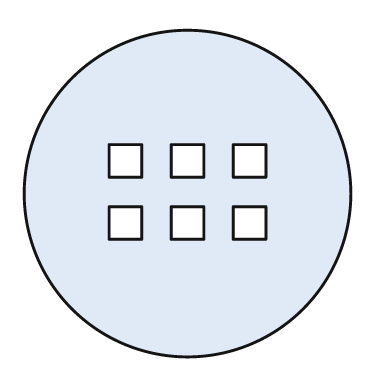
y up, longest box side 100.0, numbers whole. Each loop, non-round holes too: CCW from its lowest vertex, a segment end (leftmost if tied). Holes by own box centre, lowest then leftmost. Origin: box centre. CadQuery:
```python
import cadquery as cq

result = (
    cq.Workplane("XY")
    .moveTo(0.0, 0.0)
    .circle(50.0)
    .moveTo(-24.0, -14.0)
    .lineTo(-14.0, -14.0)
    .lineTo(-14.0, -4.0)
    .lineTo(-24.0, -4.0)
    .close()
    .moveTo(-5.0, -14.0)
    .lineTo(5.0, -14.0)
    .lineTo(5.0, -4.0)
    .lineTo(-5.0, -4.0)
    .close()
    .moveTo(14.0, -14.0)
    .lineTo(24.0, -14.0)
    .lineTo(24.0, -4.0)
    .lineTo(14.0, -4.0)
    .close()
    .moveTo(-24.0, 5.0)
    .lineTo(-14.0, 5.0)
    .lineTo(-14.0, 15.0)
    .lineTo(-24.0, 15.0)
    .close()
    .moveTo(-5.0, 5.0)
    .lineTo(5.0, 5.0)
    .lineTo(5.0, 15.0)
    .lineTo(-5.0, 15.0)
    .close()
    .moveTo(14.0, 5.0)
    .lineTo(24.0, 5.0)
    .lineTo(24.0, 15.0)
    .lineTo(14.0, 15.0)
    .close()
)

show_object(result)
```